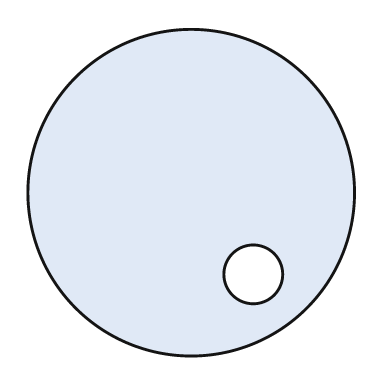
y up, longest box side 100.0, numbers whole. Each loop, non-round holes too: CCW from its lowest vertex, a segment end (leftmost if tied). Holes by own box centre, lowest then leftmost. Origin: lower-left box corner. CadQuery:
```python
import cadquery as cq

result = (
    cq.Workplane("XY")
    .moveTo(50.0, 50.0)
    .circle(50.0)
    .moveTo(69.0, 25.0)
    .circle(9.0)
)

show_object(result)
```